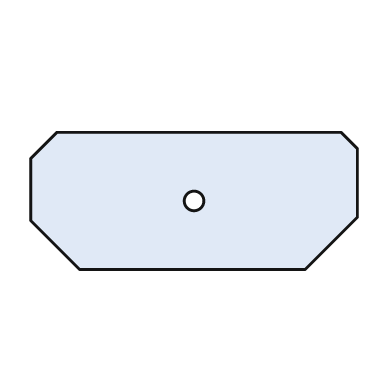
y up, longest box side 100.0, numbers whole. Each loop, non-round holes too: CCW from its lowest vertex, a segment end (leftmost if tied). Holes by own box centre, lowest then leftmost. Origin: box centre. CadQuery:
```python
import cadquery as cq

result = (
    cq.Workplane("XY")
    .moveTo(-35.0, -21.0)
    .lineTo(34.0, -21.0)
    .lineTo(50.0, -5.0)
    .lineTo(50.0, 16.0)
    .lineTo(45.0, 21.0)
    .lineTo(-42.0, 21.0)
    .lineTo(-50.0, 13.0)
    .lineTo(-50.0, -6.0)
    .close()
    .moveTo(0.0, 0.0)
    .circle(3.0)
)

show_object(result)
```